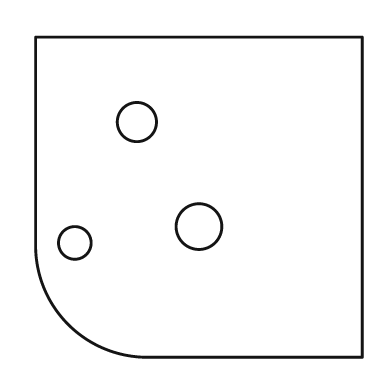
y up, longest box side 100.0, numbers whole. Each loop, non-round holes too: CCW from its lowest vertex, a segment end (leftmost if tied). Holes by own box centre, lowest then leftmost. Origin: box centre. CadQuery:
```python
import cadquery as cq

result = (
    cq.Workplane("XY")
    .moveTo(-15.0, -49.0)
    .lineTo(50.0, -49.0)
    .lineTo(50.0, 49.0)
    .lineTo(-50.0, 49.0)
    .lineTo(-50.0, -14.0)
    .threePointArc((-40.0, -39.0), (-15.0, -49.0))
    .close()
    .moveTo(-38.0, -14.0)
    .circle(5.0)
    .moveTo(0.0, -9.0)
    .circle(7.0)
    .moveTo(-19.0, 23.0)
    .circle(6.0)
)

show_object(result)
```